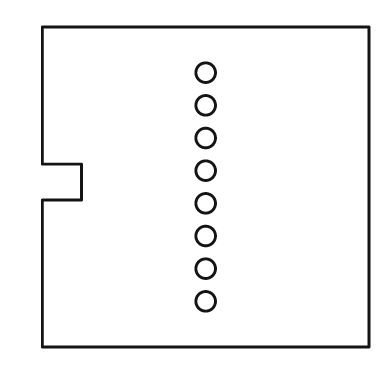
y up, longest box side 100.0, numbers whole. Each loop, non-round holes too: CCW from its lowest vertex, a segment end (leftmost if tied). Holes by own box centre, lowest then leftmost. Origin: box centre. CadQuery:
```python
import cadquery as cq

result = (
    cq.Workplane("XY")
    .moveTo(-50.0, -49.0)
    .lineTo(50.0, -49.0)
    .lineTo(50.0, 49.0)
    .lineTo(-50.0, 49.0)
    .lineTo(-50.0, 7.0)
    .lineTo(-38.0, 7.0)
    .lineTo(-38.0, -4.0)
    .lineTo(-50.0, -4.0)
    .close()
    .moveTo(0.0, -35.0)
    .circle(3.0)
    .moveTo(0.0, -25.0)
    .circle(3.0)
    .moveTo(0.0, -15.0)
    .circle(3.0)
    .moveTo(0.0, -5.0)
    .circle(3.0)
    .moveTo(0.0, 5.0)
    .circle(3.0)
    .moveTo(0.0, 15.0)
    .circle(3.0)
    .moveTo(0.0, 25.0)
    .circle(3.0)
    .moveTo(0.0, 35.0)
    .circle(3.0)
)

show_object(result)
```